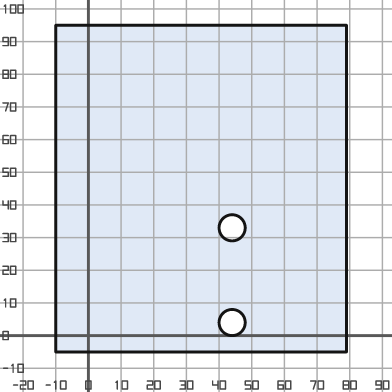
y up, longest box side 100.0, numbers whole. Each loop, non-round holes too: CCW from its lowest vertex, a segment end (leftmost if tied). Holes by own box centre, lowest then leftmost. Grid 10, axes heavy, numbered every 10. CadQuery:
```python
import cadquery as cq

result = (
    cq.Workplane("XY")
    .moveTo(-10.0, -5.0)
    .lineTo(79.0, -5.0)
    .lineTo(79.0, 95.0)
    .lineTo(-10.0, 95.0)
    .close()
    .moveTo(44.0, 4.0)
    .circle(4.0)
    .moveTo(44.0, 33.0)
    .circle(4.0)
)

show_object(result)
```